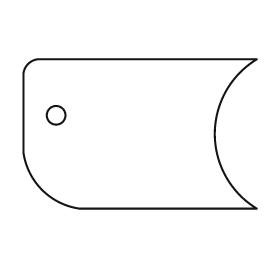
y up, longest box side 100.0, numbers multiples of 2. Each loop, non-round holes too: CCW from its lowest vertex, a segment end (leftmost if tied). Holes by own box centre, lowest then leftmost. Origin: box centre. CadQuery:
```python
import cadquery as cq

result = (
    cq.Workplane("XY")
    .moveTo(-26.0, -32.0)
    .lineTo(50.0, -32.0)
    .threePointArc((32.0, 0.0), (50.0, 32.0))
    .lineTo(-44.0, 32.0)
    .threePointArc((-48.0, 30.0), (-50.0, 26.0))
    .lineTo(-50.0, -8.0)
    .threePointArc((-42.0, -24.0), (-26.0, -32.0))
    .close()
    .moveTo(-36.0, 8.0)
    .circle(4.0)
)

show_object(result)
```